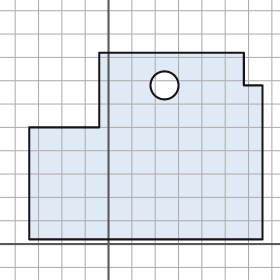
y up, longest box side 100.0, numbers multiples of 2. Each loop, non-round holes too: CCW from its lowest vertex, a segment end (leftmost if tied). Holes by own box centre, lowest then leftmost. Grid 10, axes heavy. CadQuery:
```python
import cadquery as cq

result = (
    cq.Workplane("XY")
    .moveTo(-34.0, 2.0)
    .lineTo(66.0, 2.0)
    .lineTo(66.0, 68.0)
    .lineTo(58.0, 68.0)
    .lineTo(58.0, 82.0)
    .lineTo(-4.0, 82.0)
    .lineTo(-4.0, 50.0)
    .lineTo(-34.0, 50.0)
    .close()
    .moveTo(24.0, 68.0)
    .circle(6.0)
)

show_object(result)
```